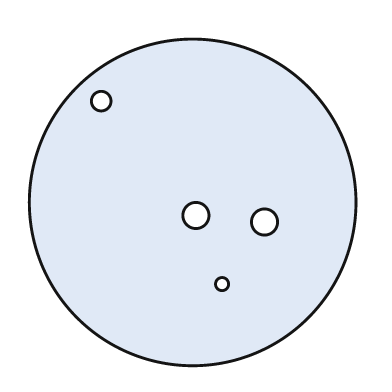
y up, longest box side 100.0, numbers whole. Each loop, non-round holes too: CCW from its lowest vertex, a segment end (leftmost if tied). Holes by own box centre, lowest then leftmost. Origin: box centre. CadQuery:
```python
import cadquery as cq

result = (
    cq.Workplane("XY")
    .moveTo(0.0, 0.0)
    .circle(50.0)
    .moveTo(9.0, -25.0)
    .circle(2.0)
    .moveTo(22.0, -6.0)
    .circle(4.0)
    .moveTo(1.0, -4.0)
    .circle(4.0)
    .moveTo(-28.0, 31.0)
    .circle(3.0)
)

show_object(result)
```